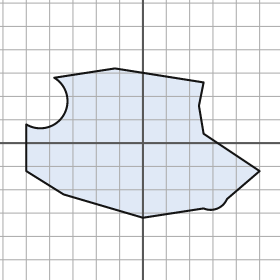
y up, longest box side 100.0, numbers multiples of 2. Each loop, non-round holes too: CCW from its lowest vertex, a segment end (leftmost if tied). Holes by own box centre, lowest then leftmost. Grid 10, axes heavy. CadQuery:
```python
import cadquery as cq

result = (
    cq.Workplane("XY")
    .moveTo(0.0, -32.0)
    .lineTo(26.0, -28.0)
    .threePointArc((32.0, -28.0), (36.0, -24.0))
    .lineTo(50.0, -12.0)
    .lineTo(26.0, 4.0)
    .lineTo(24.0, 16.0)
    .lineTo(26.0, 26.0)
    .lineTo(-12.0, 32.0)
    .lineTo(-38.0, 28.0)
    .threePointArc((-34.0, 12.0), (-50.0, 8.0))
    .lineTo(-50.0, -12.0)
    .lineTo(-34.0, -22.0)
    .close()
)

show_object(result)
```